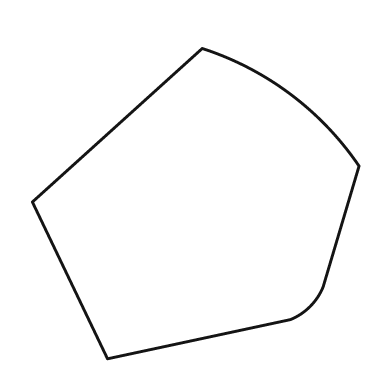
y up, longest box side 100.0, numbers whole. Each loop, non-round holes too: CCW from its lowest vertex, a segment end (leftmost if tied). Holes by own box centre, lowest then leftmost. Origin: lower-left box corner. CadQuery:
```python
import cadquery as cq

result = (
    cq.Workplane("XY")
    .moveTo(23.0, 0.0)
    .lineTo(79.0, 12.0)
    .threePointArc((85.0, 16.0), (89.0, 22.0))
    .lineTo(100.0, 59.0)
    .threePointArc((79.0, 81.0), (52.0, 95.0))
    .lineTo(0.0, 48.0)
    .close()
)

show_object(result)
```